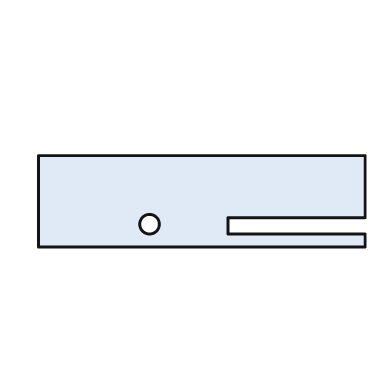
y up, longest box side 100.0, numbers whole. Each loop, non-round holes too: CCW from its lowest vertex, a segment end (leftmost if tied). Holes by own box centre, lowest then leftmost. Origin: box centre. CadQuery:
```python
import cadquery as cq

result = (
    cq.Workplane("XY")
    .moveTo(-50.0, -14.0)
    .lineTo(50.0, -14.0)
    .lineTo(50.0, -10.0)
    .lineTo(8.0, -10.0)
    .lineTo(8.0, -5.0)
    .lineTo(50.0, -5.0)
    .lineTo(50.0, 14.0)
    .lineTo(-50.0, 14.0)
    .close()
    .moveTo(-16.0, -7.0)
    .circle(3.0)
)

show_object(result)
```